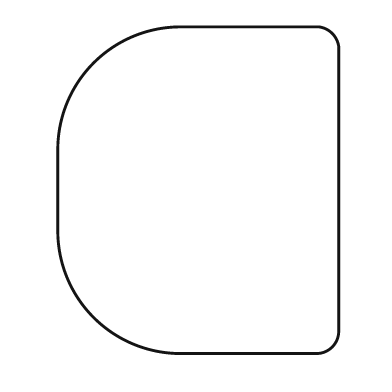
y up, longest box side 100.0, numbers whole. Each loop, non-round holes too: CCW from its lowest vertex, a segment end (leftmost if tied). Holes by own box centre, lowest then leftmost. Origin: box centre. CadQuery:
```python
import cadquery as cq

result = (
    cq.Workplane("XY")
    .moveTo(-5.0, -50.0)
    .lineTo(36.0, -50.0)
    .threePointArc((41.0, -48.0), (43.0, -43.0))
    .lineTo(43.0, 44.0)
    .threePointArc((41.0, 48.0), (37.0, 50.0))
    .lineTo(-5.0, 50.0)
    .threePointArc((-32.0, 39.0), (-43.0, 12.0))
    .lineTo(-43.0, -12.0)
    .threePointArc((-32.0, -39.0), (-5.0, -50.0))
    .close()
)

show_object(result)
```